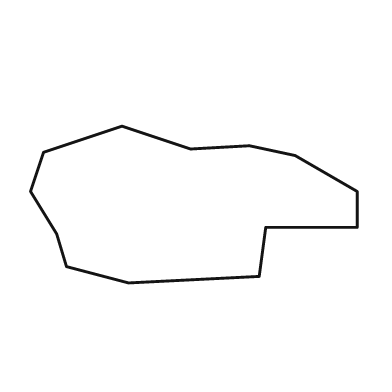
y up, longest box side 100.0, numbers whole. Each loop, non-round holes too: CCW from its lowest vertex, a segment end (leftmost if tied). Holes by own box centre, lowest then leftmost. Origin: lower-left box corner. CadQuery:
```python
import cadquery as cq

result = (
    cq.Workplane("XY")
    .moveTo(30.0, 0.0)
    .lineTo(70.0, 2.0)
    .lineTo(72.0, 17.0)
    .lineTo(100.0, 17.0)
    .lineTo(100.0, 28.0)
    .lineTo(81.0, 39.0)
    .lineTo(67.0, 42.0)
    .lineTo(49.0, 41.0)
    .lineTo(28.0, 48.0)
    .lineTo(4.0, 40.0)
    .lineTo(0.0, 28.0)
    .lineTo(8.0, 15.0)
    .lineTo(11.0, 5.0)
    .close()
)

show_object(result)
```